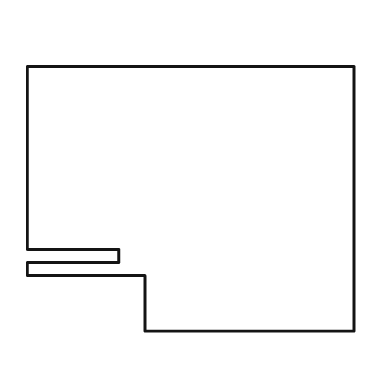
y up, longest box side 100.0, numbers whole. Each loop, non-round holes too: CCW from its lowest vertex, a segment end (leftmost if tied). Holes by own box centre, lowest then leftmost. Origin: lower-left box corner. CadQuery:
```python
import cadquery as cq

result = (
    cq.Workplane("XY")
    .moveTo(36.0, 0.0)
    .lineTo(100.0, 0.0)
    .lineTo(100.0, 81.0)
    .lineTo(0.0, 81.0)
    .lineTo(0.0, 25.0)
    .lineTo(28.0, 25.0)
    .lineTo(28.0, 21.0)
    .lineTo(0.0, 21.0)
    .lineTo(0.0, 17.0)
    .lineTo(36.0, 17.0)
    .close()
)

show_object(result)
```